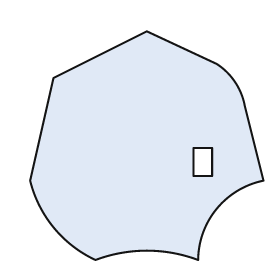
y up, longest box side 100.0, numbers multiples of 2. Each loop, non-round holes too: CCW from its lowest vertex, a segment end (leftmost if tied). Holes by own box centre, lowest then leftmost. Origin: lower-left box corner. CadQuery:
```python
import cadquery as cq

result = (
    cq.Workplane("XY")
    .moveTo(28.0, 0.0)
    .threePointArc((50.0, 4.0), (72.0, 0.0))
    .threePointArc((80.0, 22.0), (100.0, 34.0))
    .lineTo(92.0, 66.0)
    .threePointArc((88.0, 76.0), (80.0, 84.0))
    .lineTo(50.0, 98.0)
    .lineTo(10.0, 78.0)
    .lineTo(0.0, 34.0)
    .threePointArc((10.0, 14.0), (28.0, 0.0))
    .close()
    .moveTo(70.0, 36.0)
    .lineTo(78.0, 36.0)
    .lineTo(78.0, 48.0)
    .lineTo(70.0, 48.0)
    .close()
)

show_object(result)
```